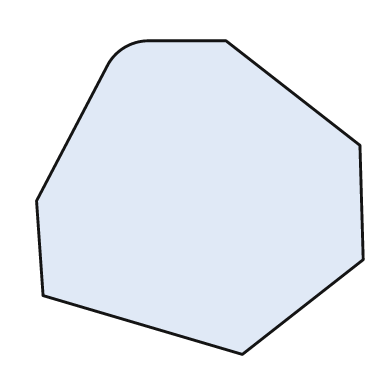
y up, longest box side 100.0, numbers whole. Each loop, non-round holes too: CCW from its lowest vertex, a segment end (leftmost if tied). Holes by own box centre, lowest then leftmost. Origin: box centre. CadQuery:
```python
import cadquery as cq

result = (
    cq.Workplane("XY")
    .moveTo(13.0, -48.0)
    .lineTo(50.0, -19.0)
    .lineTo(49.0, 16.0)
    .lineTo(8.0, 48.0)
    .lineTo(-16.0, 48.0)
    .threePointArc((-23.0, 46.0), (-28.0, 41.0))
    .lineTo(-50.0, -1.0)
    .lineTo(-48.0, -30.0)
    .close()
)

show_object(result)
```